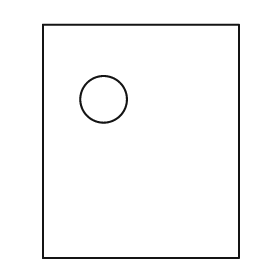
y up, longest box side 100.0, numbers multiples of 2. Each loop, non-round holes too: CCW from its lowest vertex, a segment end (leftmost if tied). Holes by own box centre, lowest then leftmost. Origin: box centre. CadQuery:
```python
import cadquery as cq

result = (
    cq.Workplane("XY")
    .moveTo(-42.0, -50.0)
    .lineTo(42.0, -50.0)
    .lineTo(42.0, 50.0)
    .lineTo(-42.0, 50.0)
    .close()
    .moveTo(-16.0, 18.0)
    .circle(10.0)
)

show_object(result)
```